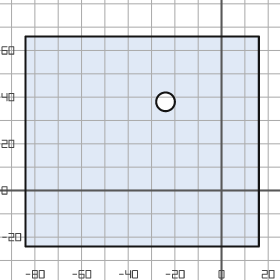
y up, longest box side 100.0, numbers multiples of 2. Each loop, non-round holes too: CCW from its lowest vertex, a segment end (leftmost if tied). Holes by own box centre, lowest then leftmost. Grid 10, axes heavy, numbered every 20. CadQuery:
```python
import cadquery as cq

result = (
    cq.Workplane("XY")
    .moveTo(-84.0, -24.0)
    .lineTo(16.0, -24.0)
    .lineTo(16.0, 66.0)
    .lineTo(-84.0, 66.0)
    .close()
    .moveTo(-24.0, 38.0)
    .circle(4.0)
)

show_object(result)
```